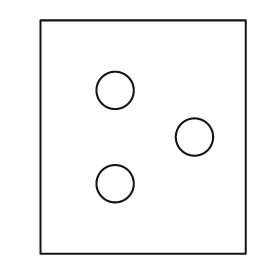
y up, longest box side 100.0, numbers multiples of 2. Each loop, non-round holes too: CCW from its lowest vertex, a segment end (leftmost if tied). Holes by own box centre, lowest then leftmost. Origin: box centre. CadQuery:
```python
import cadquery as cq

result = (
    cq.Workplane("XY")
    .moveTo(-44.0, -50.0)
    .lineTo(44.0, -50.0)
    .lineTo(44.0, 50.0)
    .lineTo(-44.0, 50.0)
    .close()
    .moveTo(-12.0, -20.0)
    .circle(8.0)
    .moveTo(22.0, 0.0)
    .circle(8.0)
    .moveTo(-12.0, 20.0)
    .circle(8.0)
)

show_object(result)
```